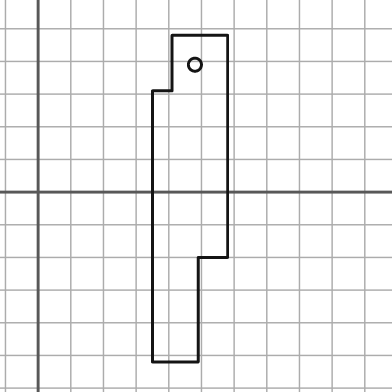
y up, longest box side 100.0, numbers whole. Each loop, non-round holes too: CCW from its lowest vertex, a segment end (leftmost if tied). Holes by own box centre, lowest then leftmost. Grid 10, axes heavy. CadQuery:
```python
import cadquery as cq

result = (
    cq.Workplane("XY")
    .moveTo(35.0, -52.0)
    .lineTo(49.0, -52.0)
    .lineTo(49.0, -20.0)
    .lineTo(58.0, -20.0)
    .lineTo(58.0, 48.0)
    .lineTo(41.0, 48.0)
    .lineTo(41.0, 31.0)
    .lineTo(35.0, 31.0)
    .close()
    .moveTo(48.0, 39.0)
    .circle(2.0)
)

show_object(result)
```